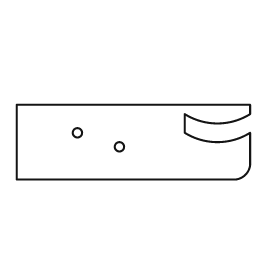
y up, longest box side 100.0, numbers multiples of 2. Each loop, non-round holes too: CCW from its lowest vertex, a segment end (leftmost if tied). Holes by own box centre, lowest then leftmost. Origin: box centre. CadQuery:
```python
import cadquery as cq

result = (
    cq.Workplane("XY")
    .moveTo(-50.0, -16.0)
    .lineTo(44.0, -16.0)
    .threePointArc((48.0, -14.0), (50.0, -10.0))
    .lineTo(50.0, 4.0)
    .threePointArc((36.0, 0.0), (22.0, 4.0))
    .lineTo(22.0, 12.0)
    .threePointArc((36.0, 8.0), (50.0, 12.0))
    .lineTo(50.0, 16.0)
    .lineTo(-50.0, 16.0)
    .close()
    .moveTo(-6.0, -2.0)
    .circle(2.0)
    .moveTo(-24.0, 4.0)
    .circle(2.0)
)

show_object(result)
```